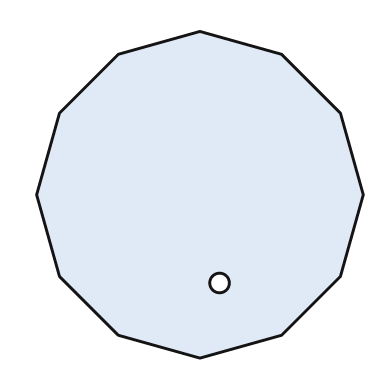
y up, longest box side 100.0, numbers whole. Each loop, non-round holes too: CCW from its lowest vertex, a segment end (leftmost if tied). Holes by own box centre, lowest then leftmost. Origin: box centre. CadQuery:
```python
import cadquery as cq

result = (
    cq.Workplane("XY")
    .moveTo(0.0, -50.0)
    .lineTo(25.0, -43.0)
    .lineTo(43.0, -25.0)
    .lineTo(50.0, 0.0)
    .lineTo(43.0, 25.0)
    .lineTo(25.0, 43.0)
    .lineTo(0.0, 50.0)
    .lineTo(-25.0, 43.0)
    .lineTo(-43.0, 25.0)
    .lineTo(-50.0, 0.0)
    .lineTo(-43.0, -25.0)
    .lineTo(-25.0, -43.0)
    .close()
    .moveTo(6.0, -27.0)
    .circle(3.0)
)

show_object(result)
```